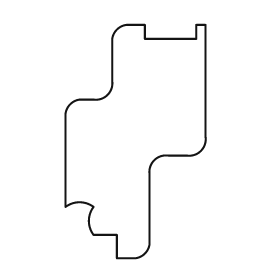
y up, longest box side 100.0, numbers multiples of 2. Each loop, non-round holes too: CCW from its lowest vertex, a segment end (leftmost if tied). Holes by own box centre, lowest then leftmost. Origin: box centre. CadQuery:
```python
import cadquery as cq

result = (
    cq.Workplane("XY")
    .moveTo(-8.0, -50.0)
    .lineTo(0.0, -50.0)
    .threePointArc((4.0, -48.0), (6.0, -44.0))
    .lineTo(6.0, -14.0)
    .threePointArc((8.0, -8.0), (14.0, -6.0))
    .lineTo(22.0, -6.0)
    .threePointArc((28.0, -4.0), (30.0, 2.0))
    .lineTo(30.0, 50.0)
    .lineTo(26.0, 50.0)
    .lineTo(26.0, 44.0)
    .lineTo(4.0, 44.0)
    .lineTo(4.0, 50.0)
    .lineTo(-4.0, 50.0)
    .threePointArc((-8.0, 48.0), (-10.0, 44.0))
    .lineTo(-10.0, 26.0)
    .threePointArc((-12.0, 20.0), (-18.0, 18.0))
    .lineTo(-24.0, 18.0)
    .threePointArc((-28.0, 16.0), (-30.0, 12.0))
    .lineTo(-30.0, -28.0)
    .threePointArc((-24.0, -26.0), (-18.0, -28.0))
    .threePointArc((-20.0, -34.0), (-18.0, -40.0))
    .lineTo(-8.0, -40.0)
    .close()
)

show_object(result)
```